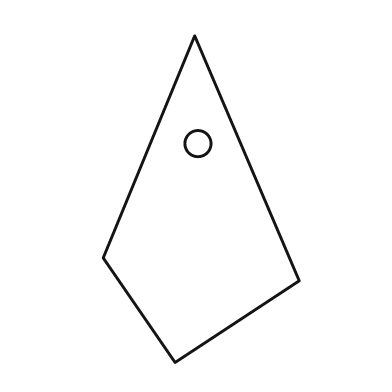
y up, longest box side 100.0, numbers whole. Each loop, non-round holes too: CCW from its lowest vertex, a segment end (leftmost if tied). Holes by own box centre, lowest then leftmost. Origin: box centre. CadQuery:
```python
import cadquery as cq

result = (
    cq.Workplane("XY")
    .moveTo(-8.0, -50.0)
    .lineTo(30.0, -25.0)
    .lineTo(-2.0, 50.0)
    .lineTo(-30.0, -18.0)
    .close()
    .moveTo(-1.0, 17.0)
    .circle(4.0)
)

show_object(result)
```